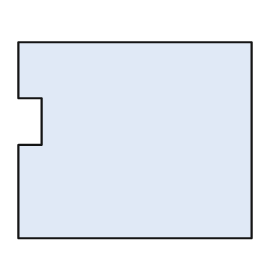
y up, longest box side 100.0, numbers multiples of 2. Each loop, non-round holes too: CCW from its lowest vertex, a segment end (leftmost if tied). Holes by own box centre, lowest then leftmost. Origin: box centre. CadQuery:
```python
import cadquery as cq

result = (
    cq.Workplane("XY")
    .moveTo(-50.0, -42.0)
    .lineTo(50.0, -42.0)
    .lineTo(50.0, 42.0)
    .lineTo(-50.0, 42.0)
    .lineTo(-50.0, 18.0)
    .lineTo(-40.0, 18.0)
    .lineTo(-40.0, -2.0)
    .lineTo(-50.0, -2.0)
    .close()
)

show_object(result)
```